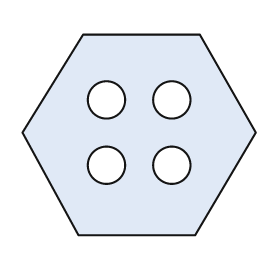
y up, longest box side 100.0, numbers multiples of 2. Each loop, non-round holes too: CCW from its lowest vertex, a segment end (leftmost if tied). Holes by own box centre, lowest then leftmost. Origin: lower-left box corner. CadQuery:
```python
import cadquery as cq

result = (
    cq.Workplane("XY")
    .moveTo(24.0, 0.0)
    .lineTo(74.0, 0.0)
    .lineTo(100.0, 44.0)
    .lineTo(76.0, 86.0)
    .lineTo(26.0, 86.0)
    .lineTo(0.0, 44.0)
    .close()
    .moveTo(36.0, 30.0)
    .circle(8.0)
    .moveTo(64.0, 30.0)
    .circle(8.0)
    .moveTo(36.0, 58.0)
    .circle(8.0)
    .moveTo(64.0, 58.0)
    .circle(8.0)
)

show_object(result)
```